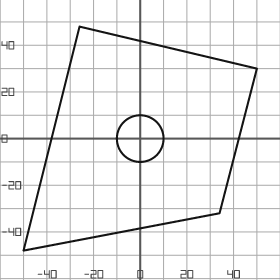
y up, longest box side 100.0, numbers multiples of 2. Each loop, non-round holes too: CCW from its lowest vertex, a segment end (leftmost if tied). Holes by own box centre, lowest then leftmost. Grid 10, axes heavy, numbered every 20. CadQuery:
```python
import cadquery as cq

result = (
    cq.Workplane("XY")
    .moveTo(-50.0, -48.0)
    .lineTo(34.0, -32.0)
    .lineTo(50.0, 30.0)
    .lineTo(-26.0, 48.0)
    .close()
    .moveTo(0.0, 0.0)
    .circle(10.0)
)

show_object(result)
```